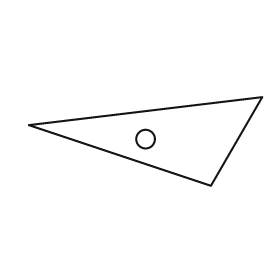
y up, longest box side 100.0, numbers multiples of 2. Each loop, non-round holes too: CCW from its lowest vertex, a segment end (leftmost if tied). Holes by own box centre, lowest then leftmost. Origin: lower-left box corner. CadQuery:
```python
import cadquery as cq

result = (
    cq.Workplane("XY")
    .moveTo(78.0, 0.0)
    .lineTo(100.0, 38.0)
    .lineTo(0.0, 26.0)
    .close()
    .moveTo(50.0, 20.0)
    .circle(4.0)
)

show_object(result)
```